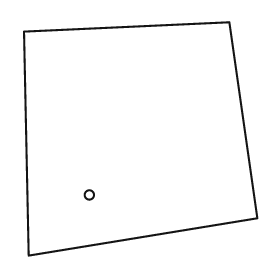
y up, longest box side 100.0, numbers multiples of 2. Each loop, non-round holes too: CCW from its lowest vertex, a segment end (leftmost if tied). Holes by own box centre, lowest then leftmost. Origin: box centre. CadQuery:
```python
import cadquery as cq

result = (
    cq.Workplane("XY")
    .moveTo(-48.0, -50.0)
    .lineTo(50.0, -34.0)
    .lineTo(38.0, 50.0)
    .lineTo(-50.0, 46.0)
    .close()
    .moveTo(-22.0, -24.0)
    .circle(2.0)
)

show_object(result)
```